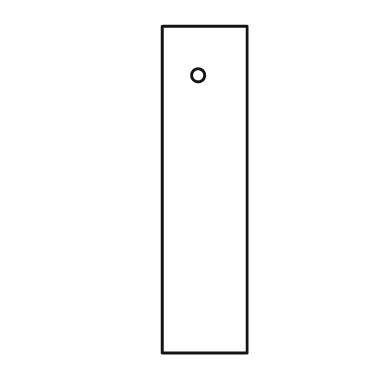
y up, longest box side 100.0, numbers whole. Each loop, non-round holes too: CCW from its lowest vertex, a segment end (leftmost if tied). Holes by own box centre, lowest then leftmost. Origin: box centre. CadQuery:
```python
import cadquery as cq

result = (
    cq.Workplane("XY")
    .moveTo(-13.0, -50.0)
    .lineTo(13.0, -50.0)
    .lineTo(13.0, 50.0)
    .lineTo(-13.0, 50.0)
    .close()
    .moveTo(-2.0, 35.0)
    .circle(2.0)
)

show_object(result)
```